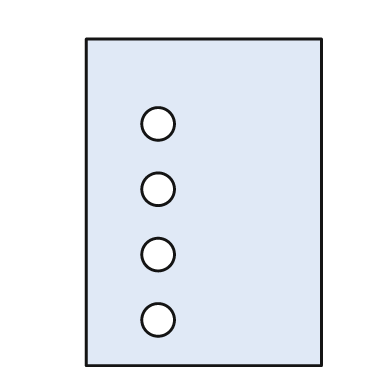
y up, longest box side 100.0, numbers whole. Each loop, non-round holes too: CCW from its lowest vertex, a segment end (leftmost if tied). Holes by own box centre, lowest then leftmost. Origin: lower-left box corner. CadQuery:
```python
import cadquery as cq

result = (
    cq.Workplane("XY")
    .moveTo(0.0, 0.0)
    .lineTo(72.0, 0.0)
    .lineTo(72.0, 100.0)
    .lineTo(0.0, 100.0)
    .close()
    .moveTo(22.0, 14.0)
    .circle(5.0)
    .moveTo(22.0, 34.0)
    .circle(5.0)
    .moveTo(22.0, 54.0)
    .circle(5.0)
    .moveTo(22.0, 74.0)
    .circle(5.0)
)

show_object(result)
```